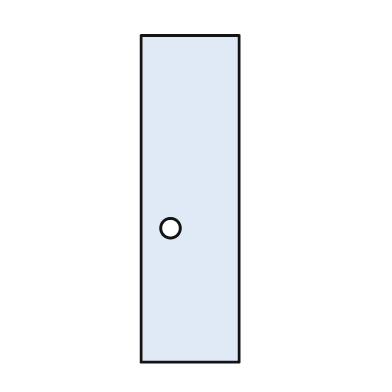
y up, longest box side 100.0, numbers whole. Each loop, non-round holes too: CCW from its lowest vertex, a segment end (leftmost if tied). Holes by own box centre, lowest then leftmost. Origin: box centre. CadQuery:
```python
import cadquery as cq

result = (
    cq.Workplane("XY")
    .moveTo(-15.0, -50.0)
    .lineTo(15.0, -50.0)
    .lineTo(15.0, 50.0)
    .lineTo(-15.0, 50.0)
    .close()
    .moveTo(-6.0, -9.0)
    .circle(3.0)
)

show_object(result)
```